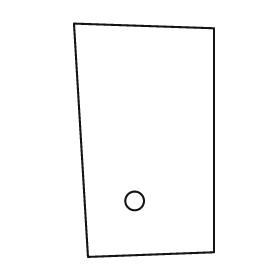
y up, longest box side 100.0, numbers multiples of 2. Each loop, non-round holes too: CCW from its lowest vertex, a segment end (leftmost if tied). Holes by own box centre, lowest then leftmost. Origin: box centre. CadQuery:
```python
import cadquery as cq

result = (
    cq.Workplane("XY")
    .moveTo(-24.0, -50.0)
    .lineTo(30.0, -48.0)
    .lineTo(30.0, 48.0)
    .lineTo(-30.0, 50.0)
    .close()
    .moveTo(-4.0, -26.0)
    .circle(4.0)
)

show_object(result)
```